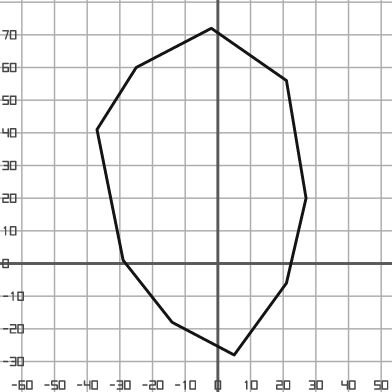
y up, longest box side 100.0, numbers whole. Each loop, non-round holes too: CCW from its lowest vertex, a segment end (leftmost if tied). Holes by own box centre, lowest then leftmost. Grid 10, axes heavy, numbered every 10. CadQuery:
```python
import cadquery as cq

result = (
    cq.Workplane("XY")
    .moveTo(5.0, -28.0)
    .lineTo(21.0, -6.0)
    .lineTo(27.0, 20.0)
    .lineTo(21.0, 56.0)
    .lineTo(-2.0, 72.0)
    .lineTo(-25.0, 60.0)
    .lineTo(-37.0, 41.0)
    .lineTo(-29.0, 1.0)
    .lineTo(-14.0, -18.0)
    .close()
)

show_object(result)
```